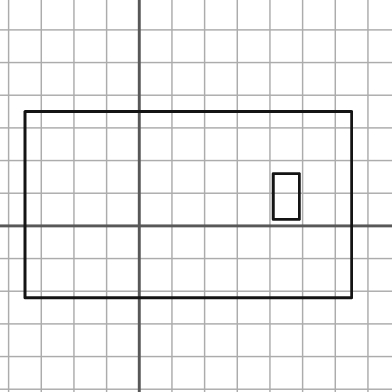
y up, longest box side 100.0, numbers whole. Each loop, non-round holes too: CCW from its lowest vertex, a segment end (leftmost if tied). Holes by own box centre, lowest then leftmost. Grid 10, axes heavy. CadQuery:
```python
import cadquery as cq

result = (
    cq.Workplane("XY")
    .moveTo(-35.0, -22.0)
    .lineTo(65.0, -22.0)
    .lineTo(65.0, 35.0)
    .lineTo(-35.0, 35.0)
    .close()
    .moveTo(41.0, 2.0)
    .lineTo(49.0, 2.0)
    .lineTo(49.0, 16.0)
    .lineTo(41.0, 16.0)
    .close()
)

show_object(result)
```